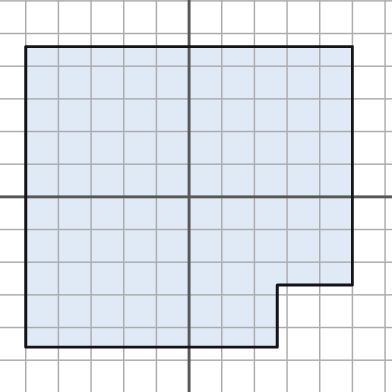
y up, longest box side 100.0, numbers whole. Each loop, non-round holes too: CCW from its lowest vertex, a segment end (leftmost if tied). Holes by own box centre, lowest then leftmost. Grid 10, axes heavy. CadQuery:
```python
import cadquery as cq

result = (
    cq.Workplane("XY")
    .moveTo(-50.0, -46.0)
    .lineTo(27.0, -46.0)
    .lineTo(27.0, -27.0)
    .lineTo(50.0, -27.0)
    .lineTo(50.0, 46.0)
    .lineTo(-50.0, 46.0)
    .close()
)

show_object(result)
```